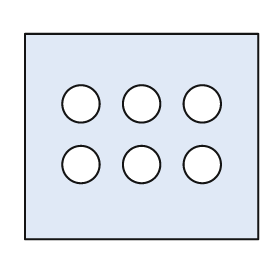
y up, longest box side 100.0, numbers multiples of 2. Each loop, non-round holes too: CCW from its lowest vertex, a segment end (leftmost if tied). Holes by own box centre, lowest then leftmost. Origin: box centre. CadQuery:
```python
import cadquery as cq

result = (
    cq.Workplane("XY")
    .moveTo(-50.0, -44.0)
    .lineTo(50.0, -44.0)
    .lineTo(50.0, 44.0)
    .lineTo(-50.0, 44.0)
    .close()
    .moveTo(-26.0, -12.0)
    .circle(8.0)
    .moveTo(0.0, -12.0)
    .circle(8.0)
    .moveTo(26.0, -12.0)
    .circle(8.0)
    .moveTo(-26.0, 14.0)
    .circle(8.0)
    .moveTo(0.0, 14.0)
    .circle(8.0)
    .moveTo(26.0, 14.0)
    .circle(8.0)
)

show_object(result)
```